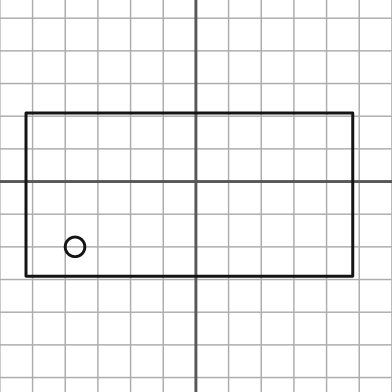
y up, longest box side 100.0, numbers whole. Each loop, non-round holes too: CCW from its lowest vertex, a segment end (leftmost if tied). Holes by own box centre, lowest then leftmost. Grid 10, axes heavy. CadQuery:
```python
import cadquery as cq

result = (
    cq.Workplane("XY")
    .moveTo(-52.0, -29.0)
    .lineTo(48.0, -29.0)
    .lineTo(48.0, 21.0)
    .lineTo(-52.0, 21.0)
    .close()
    .moveTo(-37.0, -20.0)
    .circle(3.0)
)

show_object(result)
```